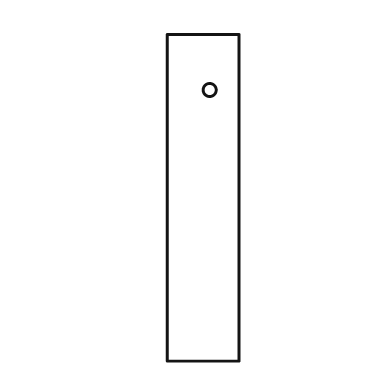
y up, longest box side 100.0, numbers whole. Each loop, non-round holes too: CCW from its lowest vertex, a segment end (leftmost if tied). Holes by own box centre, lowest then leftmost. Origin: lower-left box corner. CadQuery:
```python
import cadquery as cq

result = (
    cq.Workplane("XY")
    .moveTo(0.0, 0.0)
    .lineTo(22.0, 0.0)
    .lineTo(22.0, 100.0)
    .lineTo(0.0, 100.0)
    .close()
    .moveTo(13.0, 83.0)
    .circle(2.0)
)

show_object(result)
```